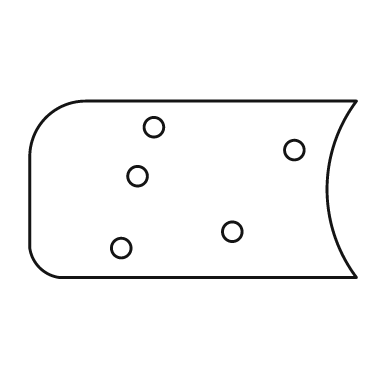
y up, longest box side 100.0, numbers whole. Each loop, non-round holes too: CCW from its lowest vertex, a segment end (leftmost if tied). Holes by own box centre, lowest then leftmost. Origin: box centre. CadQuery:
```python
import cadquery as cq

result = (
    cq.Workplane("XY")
    .moveTo(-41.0, -27.0)
    .lineTo(50.0, -27.0)
    .threePointArc((41.0, 0.0), (50.0, 27.0))
    .lineTo(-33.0, 27.0)
    .threePointArc((-45.0, 22.0), (-50.0, 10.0))
    .lineTo(-50.0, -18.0)
    .threePointArc((-47.0, -24.0), (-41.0, -27.0))
    .close()
    .moveTo(-22.0, -18.0)
    .circle(3.0)
    .moveTo(12.0, -13.0)
    .circle(3.0)
    .moveTo(-17.0, 4.0)
    .circle(3.0)
    .moveTo(31.0, 12.0)
    .circle(3.0)
    .moveTo(-12.0, 19.0)
    .circle(3.0)
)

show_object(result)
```